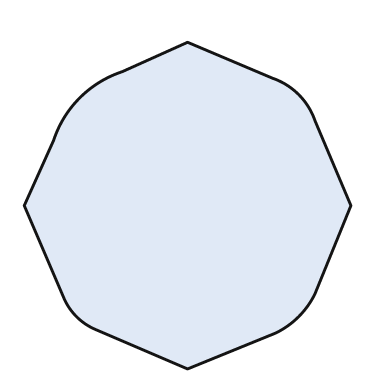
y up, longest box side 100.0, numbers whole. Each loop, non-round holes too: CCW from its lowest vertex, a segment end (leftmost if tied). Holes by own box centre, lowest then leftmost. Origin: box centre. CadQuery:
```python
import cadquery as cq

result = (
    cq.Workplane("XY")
    .moveTo(0.0, -50.0)
    .lineTo(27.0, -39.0)
    .threePointArc((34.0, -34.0), (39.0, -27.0))
    .lineTo(50.0, 0.0)
    .lineTo(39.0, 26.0)
    .threePointArc((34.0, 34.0), (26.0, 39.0))
    .lineTo(0.0, 50.0)
    .lineTo(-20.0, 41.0)
    .threePointArc((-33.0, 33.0), (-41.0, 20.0))
    .lineTo(-50.0, 0.0)
    .lineTo(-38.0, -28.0)
    .threePointArc((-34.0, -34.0), (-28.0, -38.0))
    .close()
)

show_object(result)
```